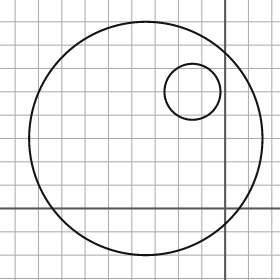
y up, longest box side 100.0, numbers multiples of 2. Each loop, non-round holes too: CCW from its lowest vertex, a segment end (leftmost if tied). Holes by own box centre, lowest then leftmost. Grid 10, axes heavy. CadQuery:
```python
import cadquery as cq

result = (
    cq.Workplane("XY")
    .moveTo(-34.0, 30.0)
    .circle(50.0)
    .moveTo(-14.0, 50.0)
    .circle(12.0)
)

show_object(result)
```